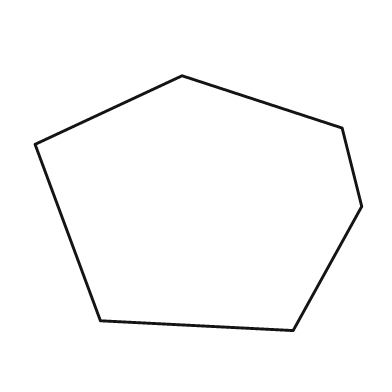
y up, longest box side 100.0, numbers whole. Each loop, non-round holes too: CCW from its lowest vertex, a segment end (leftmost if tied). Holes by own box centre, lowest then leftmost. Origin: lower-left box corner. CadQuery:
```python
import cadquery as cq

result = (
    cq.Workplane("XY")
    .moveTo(79.0, 0.0)
    .lineTo(100.0, 38.0)
    .lineTo(94.0, 62.0)
    .lineTo(45.0, 78.0)
    .lineTo(0.0, 57.0)
    .lineTo(20.0, 3.0)
    .close()
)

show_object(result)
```